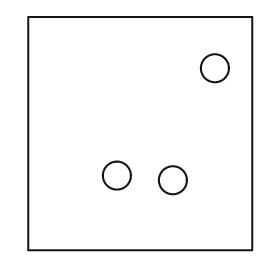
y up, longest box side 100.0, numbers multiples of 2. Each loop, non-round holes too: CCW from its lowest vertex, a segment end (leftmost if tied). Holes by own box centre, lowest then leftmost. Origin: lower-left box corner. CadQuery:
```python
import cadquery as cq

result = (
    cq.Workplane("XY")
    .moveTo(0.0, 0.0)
    .lineTo(96.0, 0.0)
    .lineTo(96.0, 100.0)
    .lineTo(0.0, 100.0)
    .close()
    .moveTo(62.0, 30.0)
    .circle(6.0)
    .moveTo(38.0, 32.0)
    .circle(6.0)
    .moveTo(80.0, 78.0)
    .circle(6.0)
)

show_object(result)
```